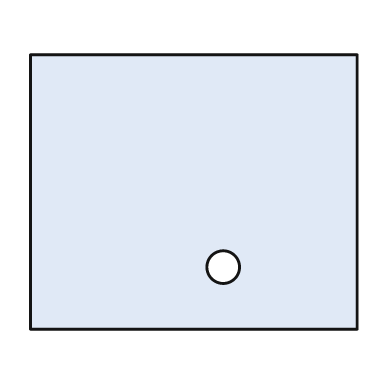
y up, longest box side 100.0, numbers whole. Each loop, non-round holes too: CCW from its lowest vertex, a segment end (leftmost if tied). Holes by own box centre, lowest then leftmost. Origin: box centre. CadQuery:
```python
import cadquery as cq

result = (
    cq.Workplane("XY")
    .moveTo(-50.0, -42.0)
    .lineTo(50.0, -42.0)
    .lineTo(50.0, 42.0)
    .lineTo(-50.0, 42.0)
    .close()
    .moveTo(9.0, -23.0)
    .circle(5.0)
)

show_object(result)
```